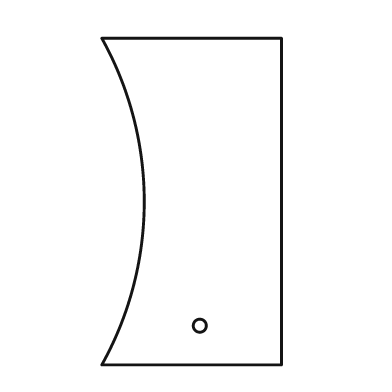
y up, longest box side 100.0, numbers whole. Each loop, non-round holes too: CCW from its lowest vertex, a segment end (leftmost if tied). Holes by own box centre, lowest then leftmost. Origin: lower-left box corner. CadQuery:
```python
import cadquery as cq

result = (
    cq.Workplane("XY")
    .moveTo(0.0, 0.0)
    .lineTo(55.0, 0.0)
    .lineTo(55.0, 100.0)
    .lineTo(0.0, 100.0)
    .threePointArc((13.0, 50.0), (0.0, 0.0))
    .close()
    .moveTo(30.0, 12.0)
    .circle(2.0)
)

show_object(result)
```